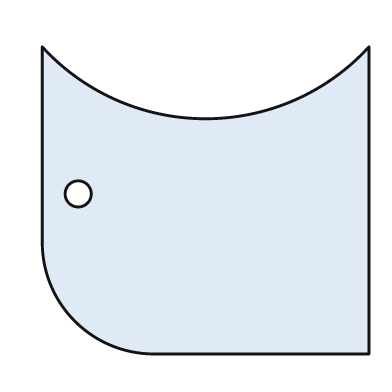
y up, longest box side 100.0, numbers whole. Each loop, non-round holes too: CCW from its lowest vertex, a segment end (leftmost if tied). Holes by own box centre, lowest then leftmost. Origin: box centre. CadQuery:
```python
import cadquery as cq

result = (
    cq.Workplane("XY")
    .moveTo(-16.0, -47.0)
    .lineTo(50.0, -47.0)
    .lineTo(50.0, 47.0)
    .threePointArc((0.0, 25.0), (-50.0, 47.0))
    .lineTo(-50.0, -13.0)
    .threePointArc((-40.0, -37.0), (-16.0, -47.0))
    .close()
    .moveTo(-39.0, 2.0)
    .circle(4.0)
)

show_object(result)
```